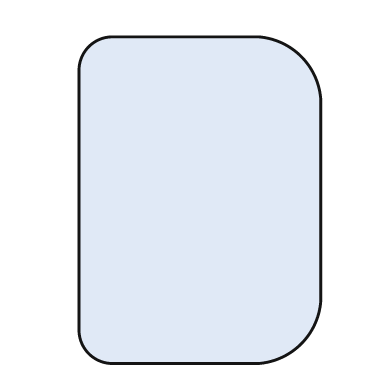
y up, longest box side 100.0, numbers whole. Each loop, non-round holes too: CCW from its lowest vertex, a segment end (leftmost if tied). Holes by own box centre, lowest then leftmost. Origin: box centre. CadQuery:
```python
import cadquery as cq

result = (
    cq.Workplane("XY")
    .moveTo(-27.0, -50.0)
    .lineTo(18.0, -50.0)
    .threePointArc((31.0, -44.0), (37.0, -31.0))
    .lineTo(37.0, 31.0)
    .threePointArc((31.0, 44.0), (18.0, 50.0))
    .lineTo(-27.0, 50.0)
    .threePointArc((-34.0, 47.0), (-37.0, 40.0))
    .lineTo(-37.0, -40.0)
    .threePointArc((-34.0, -47.0), (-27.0, -50.0))
    .close()
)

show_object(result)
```